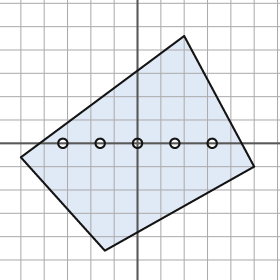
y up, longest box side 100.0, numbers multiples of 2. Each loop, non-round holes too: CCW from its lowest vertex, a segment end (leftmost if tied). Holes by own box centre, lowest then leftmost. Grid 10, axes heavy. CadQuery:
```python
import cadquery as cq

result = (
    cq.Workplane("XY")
    .moveTo(-14.0, -46.0)
    .lineTo(50.0, -10.0)
    .lineTo(20.0, 46.0)
    .lineTo(-50.0, -6.0)
    .close()
    .moveTo(-32.0, 0.0)
    .circle(2.0)
    .moveTo(-16.0, 0.0)
    .circle(2.0)
    .moveTo(0.0, 0.0)
    .circle(2.0)
    .moveTo(16.0, 0.0)
    .circle(2.0)
    .moveTo(32.0, 0.0)
    .circle(2.0)
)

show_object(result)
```